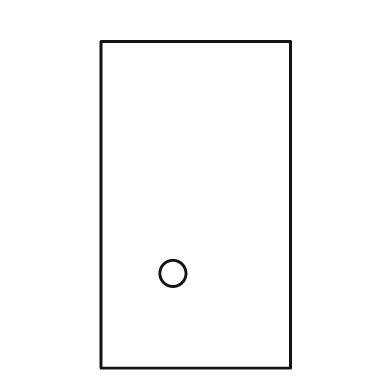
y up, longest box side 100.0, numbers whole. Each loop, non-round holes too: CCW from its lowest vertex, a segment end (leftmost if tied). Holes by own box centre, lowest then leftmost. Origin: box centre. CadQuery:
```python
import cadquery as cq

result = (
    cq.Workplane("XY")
    .moveTo(-29.0, -50.0)
    .lineTo(29.0, -50.0)
    .lineTo(29.0, 50.0)
    .lineTo(-29.0, 50.0)
    .close()
    .moveTo(-7.0, -21.0)
    .circle(4.0)
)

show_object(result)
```